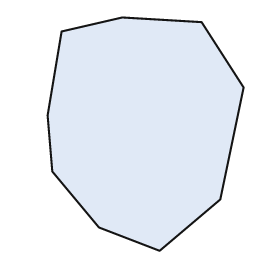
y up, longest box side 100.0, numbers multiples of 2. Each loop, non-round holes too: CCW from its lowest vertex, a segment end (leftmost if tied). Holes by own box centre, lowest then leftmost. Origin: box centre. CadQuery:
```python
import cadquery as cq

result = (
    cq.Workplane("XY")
    .moveTo(6.0, -50.0)
    .lineTo(32.0, -28.0)
    .lineTo(42.0, 20.0)
    .lineTo(24.0, 48.0)
    .lineTo(-10.0, 50.0)
    .lineTo(-36.0, 44.0)
    .lineTo(-42.0, 8.0)
    .lineTo(-40.0, -16.0)
    .lineTo(-20.0, -40.0)
    .close()
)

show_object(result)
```